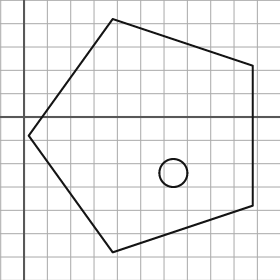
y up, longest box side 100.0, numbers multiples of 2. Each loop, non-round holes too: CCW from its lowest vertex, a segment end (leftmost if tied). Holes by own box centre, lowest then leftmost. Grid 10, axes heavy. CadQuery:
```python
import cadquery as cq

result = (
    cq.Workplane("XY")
    .moveTo(38.0, -58.0)
    .lineTo(98.0, -38.0)
    .lineTo(98.0, 22.0)
    .lineTo(38.0, 42.0)
    .lineTo(2.0, -8.0)
    .close()
    .moveTo(64.0, -24.0)
    .circle(6.0)
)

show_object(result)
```